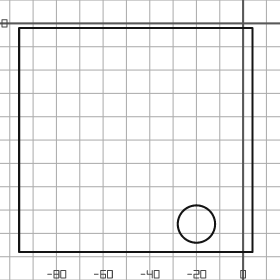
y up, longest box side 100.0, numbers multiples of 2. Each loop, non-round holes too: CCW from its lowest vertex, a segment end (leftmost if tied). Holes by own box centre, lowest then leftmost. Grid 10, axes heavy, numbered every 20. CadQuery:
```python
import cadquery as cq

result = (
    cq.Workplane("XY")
    .moveTo(-96.0, -98.0)
    .lineTo(4.0, -98.0)
    .lineTo(4.0, -2.0)
    .lineTo(-96.0, -2.0)
    .close()
    .moveTo(-20.0, -86.0)
    .circle(8.0)
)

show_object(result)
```